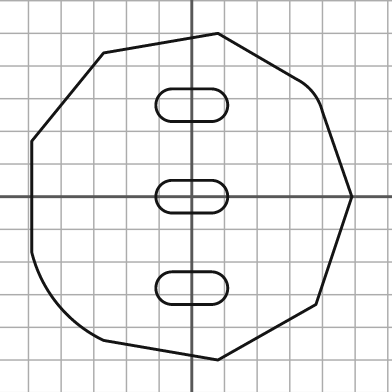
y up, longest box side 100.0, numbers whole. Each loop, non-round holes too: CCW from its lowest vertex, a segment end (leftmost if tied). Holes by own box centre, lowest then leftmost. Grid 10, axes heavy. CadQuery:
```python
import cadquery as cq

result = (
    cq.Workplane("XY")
    .moveTo(8.0, -50.0)
    .lineTo(38.0, -33.0)
    .lineTo(49.0, 0.0)
    .lineTo(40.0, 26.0)
    .threePointArc((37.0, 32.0), (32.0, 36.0))
    .lineTo(8.0, 50.0)
    .lineTo(-27.0, 44.0)
    .lineTo(-49.0, 17.0)
    .lineTo(-49.0, -17.0)
    .threePointArc((-41.0, -33.0), (-27.0, -44.0))
    .close()
    .moveTo(-6.0, -33.0)
    .lineTo(6.0, -33.0)
    .threePointArc((11.0, -28.0), (6.0, -23.0))
    .lineTo(-6.0, -23.0)
    .threePointArc((-11.0, -28.0), (-6.0, -33.0))
    .close()
    .moveTo(-6.0, -5.0)
    .lineTo(6.0, -5.0)
    .threePointArc((11.0, 0.0), (6.0, 5.0))
    .lineTo(-6.0, 5.0)
    .threePointArc((-11.0, 0.0), (-6.0, -5.0))
    .close()
    .moveTo(-6.0, 23.0)
    .lineTo(6.0, 23.0)
    .threePointArc((11.0, 28.0), (6.0, 33.0))
    .lineTo(-6.0, 33.0)
    .threePointArc((-11.0, 28.0), (-6.0, 23.0))
    .close()
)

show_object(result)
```